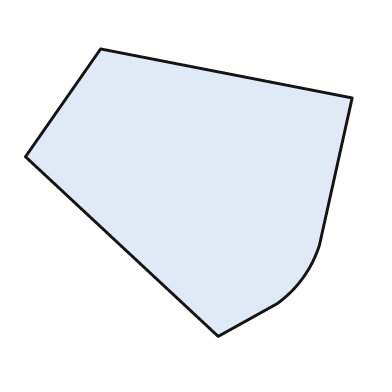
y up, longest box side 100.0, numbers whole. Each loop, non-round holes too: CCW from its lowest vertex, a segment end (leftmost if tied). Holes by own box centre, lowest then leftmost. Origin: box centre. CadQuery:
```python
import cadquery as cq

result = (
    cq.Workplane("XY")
    .moveTo(9.0, -44.0)
    .lineTo(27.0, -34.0)
    .threePointArc((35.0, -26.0), (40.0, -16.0))
    .lineTo(50.0, 29.0)
    .lineTo(-27.0, 44.0)
    .lineTo(-50.0, 11.0)
    .close()
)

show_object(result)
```